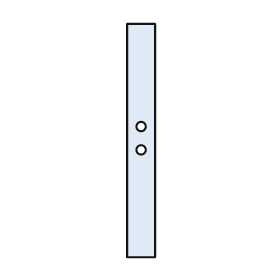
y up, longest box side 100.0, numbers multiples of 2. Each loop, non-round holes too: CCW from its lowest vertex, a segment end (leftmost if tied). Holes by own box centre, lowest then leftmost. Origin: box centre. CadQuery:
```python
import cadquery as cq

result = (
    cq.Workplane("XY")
    .moveTo(-6.0, -50.0)
    .lineTo(6.0, -50.0)
    .lineTo(6.0, 50.0)
    .lineTo(-6.0, 50.0)
    .close()
    .moveTo(0.0, -4.0)
    .circle(2.0)
    .moveTo(0.0, 6.0)
    .circle(2.0)
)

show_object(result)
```